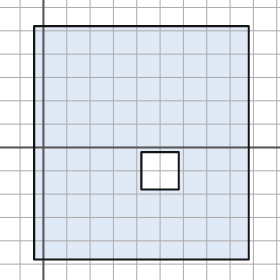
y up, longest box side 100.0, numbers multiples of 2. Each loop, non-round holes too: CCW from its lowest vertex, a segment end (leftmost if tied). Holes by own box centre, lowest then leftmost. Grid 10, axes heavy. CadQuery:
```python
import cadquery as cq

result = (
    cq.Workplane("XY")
    .moveTo(-4.0, -48.0)
    .lineTo(88.0, -48.0)
    .lineTo(88.0, 52.0)
    .lineTo(-4.0, 52.0)
    .close()
    .moveTo(42.0, -18.0)
    .lineTo(58.0, -18.0)
    .lineTo(58.0, -2.0)
    .lineTo(42.0, -2.0)
    .close()
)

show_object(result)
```